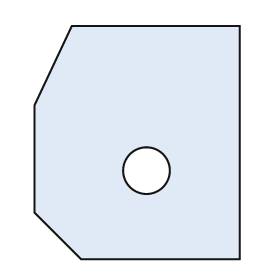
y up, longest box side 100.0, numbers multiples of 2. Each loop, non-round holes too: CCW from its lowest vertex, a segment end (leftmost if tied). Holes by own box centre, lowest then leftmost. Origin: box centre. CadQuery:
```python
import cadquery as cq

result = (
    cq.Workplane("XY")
    .moveTo(-24.0, -50.0)
    .lineTo(44.0, -50.0)
    .lineTo(44.0, 50.0)
    .lineTo(-28.0, 50.0)
    .lineTo(-44.0, 16.0)
    .lineTo(-44.0, -30.0)
    .close()
    .moveTo(4.0, -12.0)
    .circle(10.0)
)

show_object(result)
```